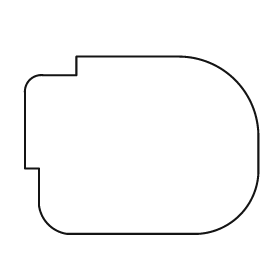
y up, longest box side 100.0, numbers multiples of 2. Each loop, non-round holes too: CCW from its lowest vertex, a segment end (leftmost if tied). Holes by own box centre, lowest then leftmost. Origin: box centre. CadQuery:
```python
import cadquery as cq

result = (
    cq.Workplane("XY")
    .moveTo(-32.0, -38.0)
    .lineTo(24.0, -38.0)
    .threePointArc((42.0, -30.0), (50.0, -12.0))
    .lineTo(50.0, 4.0)
    .threePointArc((40.0, 28.0), (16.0, 38.0))
    .lineTo(-28.0, 38.0)
    .lineTo(-28.0, 30.0)
    .lineTo(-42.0, 30.0)
    .threePointArc((-48.0, 28.0), (-50.0, 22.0))
    .lineTo(-50.0, -10.0)
    .lineTo(-44.0, -10.0)
    .lineTo(-44.0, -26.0)
    .threePointArc((-40.0, -34.0), (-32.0, -38.0))
    .close()
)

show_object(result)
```